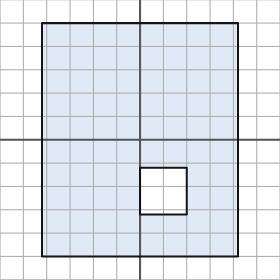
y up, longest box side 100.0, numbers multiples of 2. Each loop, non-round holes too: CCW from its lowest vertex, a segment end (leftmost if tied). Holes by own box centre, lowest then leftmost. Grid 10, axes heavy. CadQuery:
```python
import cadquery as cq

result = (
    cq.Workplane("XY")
    .moveTo(-42.0, -50.0)
    .lineTo(42.0, -50.0)
    .lineTo(42.0, 50.0)
    .lineTo(-42.0, 50.0)
    .close()
    .moveTo(0.0, -32.0)
    .lineTo(20.0, -32.0)
    .lineTo(20.0, -12.0)
    .lineTo(0.0, -12.0)
    .close()
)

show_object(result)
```